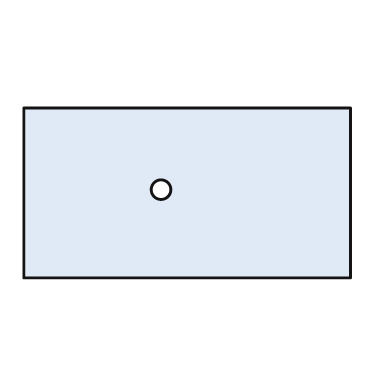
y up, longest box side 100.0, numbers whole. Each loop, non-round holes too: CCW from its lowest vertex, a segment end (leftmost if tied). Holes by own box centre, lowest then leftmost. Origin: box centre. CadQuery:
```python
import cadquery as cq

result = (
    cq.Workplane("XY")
    .moveTo(-50.0, -26.0)
    .lineTo(50.0, -26.0)
    .lineTo(50.0, 26.0)
    .lineTo(-50.0, 26.0)
    .close()
    .moveTo(-8.0, 1.0)
    .circle(3.0)
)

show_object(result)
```